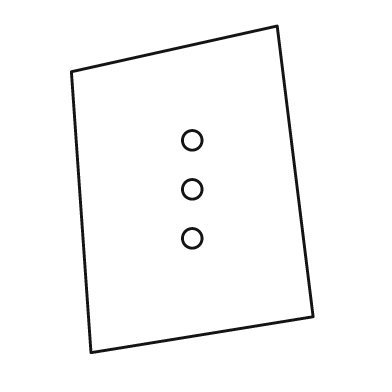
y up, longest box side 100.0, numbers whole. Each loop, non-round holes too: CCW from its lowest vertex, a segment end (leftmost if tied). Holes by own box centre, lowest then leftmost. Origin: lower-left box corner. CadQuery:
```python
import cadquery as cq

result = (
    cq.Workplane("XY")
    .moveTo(6.0, 0.0)
    .lineTo(74.0, 11.0)
    .lineTo(63.0, 100.0)
    .lineTo(0.0, 86.0)
    .close()
    .moveTo(37.0, 35.0)
    .circle(3.0)
    .moveTo(37.0, 50.0)
    .circle(3.0)
    .moveTo(37.0, 65.0)
    .circle(3.0)
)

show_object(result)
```